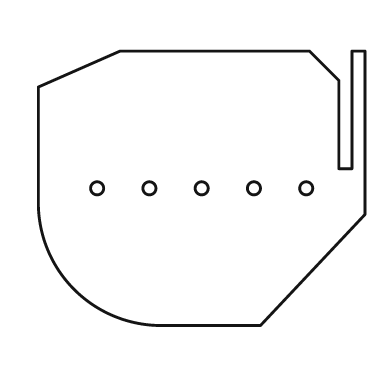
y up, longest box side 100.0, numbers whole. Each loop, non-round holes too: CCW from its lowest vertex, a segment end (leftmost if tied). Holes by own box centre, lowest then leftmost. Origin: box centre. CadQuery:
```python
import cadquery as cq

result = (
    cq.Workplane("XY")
    .moveTo(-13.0, -42.0)
    .lineTo(18.0, -42.0)
    .lineTo(50.0, -8.0)
    .lineTo(50.0, 42.0)
    .lineTo(46.0, 42.0)
    .lineTo(46.0, 6.0)
    .lineTo(42.0, 6.0)
    .lineTo(42.0, 33.0)
    .lineTo(33.0, 42.0)
    .lineTo(-25.0, 42.0)
    .lineTo(-50.0, 31.0)
    .lineTo(-50.0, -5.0)
    .threePointArc((-39.0, -31.0), (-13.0, -42.0))
    .close()
    .moveTo(-32.0, 0.0)
    .circle(2.0)
    .moveTo(-16.0, 0.0)
    .circle(2.0)
    .moveTo(0.0, 0.0)
    .circle(2.0)
    .moveTo(16.0, 0.0)
    .circle(2.0)
    .moveTo(32.0, 0.0)
    .circle(2.0)
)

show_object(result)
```